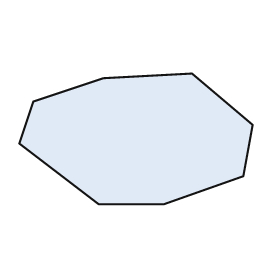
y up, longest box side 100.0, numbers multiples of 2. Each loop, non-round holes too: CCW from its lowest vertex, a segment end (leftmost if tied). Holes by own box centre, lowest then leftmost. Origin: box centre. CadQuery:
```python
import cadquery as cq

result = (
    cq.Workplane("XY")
    .moveTo(-16.0, -28.0)
    .lineTo(12.0, -28.0)
    .lineTo(46.0, -16.0)
    .lineTo(50.0, 6.0)
    .lineTo(24.0, 28.0)
    .lineTo(-14.0, 26.0)
    .lineTo(-44.0, 16.0)
    .lineTo(-50.0, -2.0)
    .close()
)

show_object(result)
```